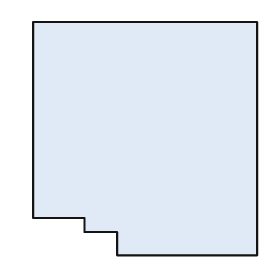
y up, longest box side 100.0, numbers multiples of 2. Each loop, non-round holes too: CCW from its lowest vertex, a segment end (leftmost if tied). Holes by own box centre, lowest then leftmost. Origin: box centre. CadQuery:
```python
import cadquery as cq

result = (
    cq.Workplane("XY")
    .moveTo(-12.0, -50.0)
    .lineTo(48.0, -50.0)
    .lineTo(48.0, 50.0)
    .lineTo(-48.0, 50.0)
    .lineTo(-48.0, -34.0)
    .lineTo(-26.0, -34.0)
    .lineTo(-26.0, -40.0)
    .lineTo(-12.0, -40.0)
    .close()
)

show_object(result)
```